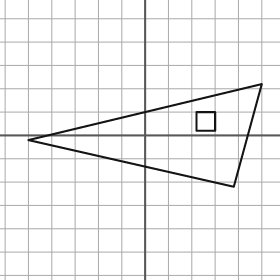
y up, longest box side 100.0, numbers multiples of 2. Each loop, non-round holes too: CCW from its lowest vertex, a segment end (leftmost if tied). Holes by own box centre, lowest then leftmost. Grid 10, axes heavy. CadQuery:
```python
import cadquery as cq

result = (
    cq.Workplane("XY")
    .moveTo(38.0, -22.0)
    .lineTo(50.0, 22.0)
    .lineTo(-50.0, -2.0)
    .close()
    .moveTo(22.0, 2.0)
    .lineTo(30.0, 2.0)
    .lineTo(30.0, 10.0)
    .lineTo(22.0, 10.0)
    .close()
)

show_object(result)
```